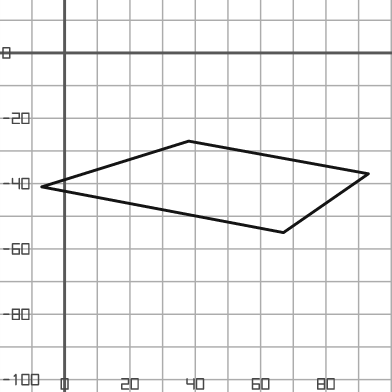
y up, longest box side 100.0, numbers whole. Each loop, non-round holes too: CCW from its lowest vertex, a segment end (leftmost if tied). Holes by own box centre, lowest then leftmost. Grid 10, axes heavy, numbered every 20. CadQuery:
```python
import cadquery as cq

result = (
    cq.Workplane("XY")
    .moveTo(67.0, -55.0)
    .lineTo(93.0, -37.0)
    .lineTo(38.0, -27.0)
    .lineTo(-7.0, -41.0)
    .close()
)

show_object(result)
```